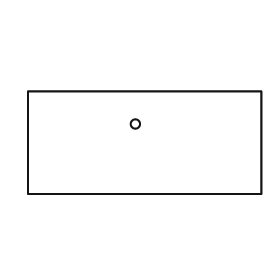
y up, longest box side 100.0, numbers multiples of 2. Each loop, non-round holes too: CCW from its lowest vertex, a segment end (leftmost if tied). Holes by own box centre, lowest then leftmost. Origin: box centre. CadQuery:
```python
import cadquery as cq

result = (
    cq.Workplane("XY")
    .moveTo(-50.0, -22.0)
    .lineTo(50.0, -22.0)
    .lineTo(50.0, 22.0)
    .lineTo(-50.0, 22.0)
    .close()
    .moveTo(-4.0, 8.0)
    .circle(2.0)
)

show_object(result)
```